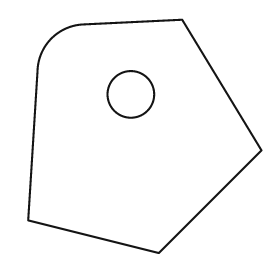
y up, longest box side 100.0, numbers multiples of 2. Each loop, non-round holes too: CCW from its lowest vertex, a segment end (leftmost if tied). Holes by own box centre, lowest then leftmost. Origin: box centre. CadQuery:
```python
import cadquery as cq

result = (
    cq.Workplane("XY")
    .moveTo(6.0, -50.0)
    .lineTo(50.0, -6.0)
    .lineTo(16.0, 50.0)
    .lineTo(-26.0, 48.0)
    .threePointArc((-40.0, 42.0), (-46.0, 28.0))
    .lineTo(-50.0, -36.0)
    .close()
    .moveTo(-6.0, 18.0)
    .circle(10.0)
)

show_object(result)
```